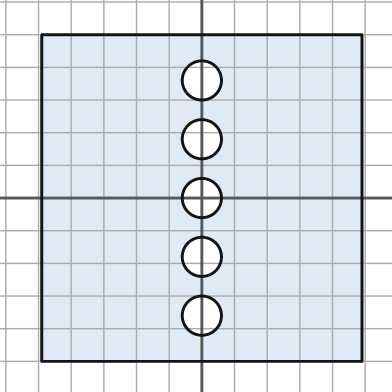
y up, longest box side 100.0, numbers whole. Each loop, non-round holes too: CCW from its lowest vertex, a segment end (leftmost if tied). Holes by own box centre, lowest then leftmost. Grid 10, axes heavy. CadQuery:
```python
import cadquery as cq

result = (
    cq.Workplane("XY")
    .moveTo(-49.0, -50.0)
    .lineTo(49.0, -50.0)
    .lineTo(49.0, 50.0)
    .lineTo(-49.0, 50.0)
    .close()
    .moveTo(0.0, -36.0)
    .circle(6.0)
    .moveTo(0.0, -18.0)
    .circle(6.0)
    .moveTo(0.0, 0.0)
    .circle(6.0)
    .moveTo(0.0, 18.0)
    .circle(6.0)
    .moveTo(0.0, 36.0)
    .circle(6.0)
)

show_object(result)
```